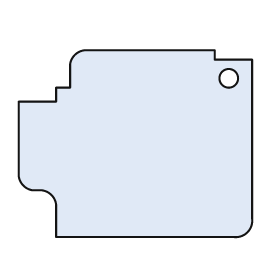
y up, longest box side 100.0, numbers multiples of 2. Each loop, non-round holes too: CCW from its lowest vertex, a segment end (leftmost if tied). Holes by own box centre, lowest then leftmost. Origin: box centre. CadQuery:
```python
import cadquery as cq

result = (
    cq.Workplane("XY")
    .moveTo(-34.0, -40.0)
    .lineTo(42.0, -40.0)
    .threePointArc((48.0, -38.0), (50.0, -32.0))
    .lineTo(50.0, 36.0)
    .lineTo(34.0, 36.0)
    .lineTo(34.0, 40.0)
    .lineTo(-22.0, 40.0)
    .threePointArc((-26.0, 38.0), (-28.0, 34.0))
    .lineTo(-28.0, 24.0)
    .lineTo(-34.0, 24.0)
    .lineTo(-34.0, 18.0)
    .lineTo(-50.0, 18.0)
    .lineTo(-50.0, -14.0)
    .threePointArc((-48.0, -18.0), (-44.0, -20.0))
    .lineTo(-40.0, -20.0)
    .threePointArc((-36.0, -22.0), (-34.0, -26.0))
    .close()
    .moveTo(40.0, 28.0)
    .circle(4.0)
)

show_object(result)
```